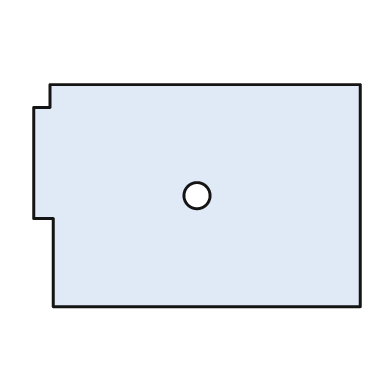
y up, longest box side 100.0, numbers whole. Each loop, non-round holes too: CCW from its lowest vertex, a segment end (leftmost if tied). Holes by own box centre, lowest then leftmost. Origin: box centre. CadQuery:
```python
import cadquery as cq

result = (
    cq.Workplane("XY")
    .moveTo(-44.0, -34.0)
    .lineTo(50.0, -34.0)
    .lineTo(50.0, 34.0)
    .lineTo(-45.0, 34.0)
    .lineTo(-45.0, 27.0)
    .lineTo(-50.0, 27.0)
    .lineTo(-50.0, -7.0)
    .lineTo(-44.0, -7.0)
    .close()
    .moveTo(0.0, 0.0)
    .circle(4.0)
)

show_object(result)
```